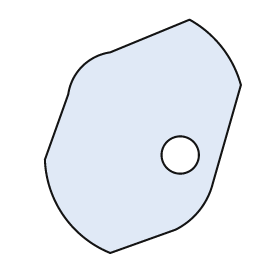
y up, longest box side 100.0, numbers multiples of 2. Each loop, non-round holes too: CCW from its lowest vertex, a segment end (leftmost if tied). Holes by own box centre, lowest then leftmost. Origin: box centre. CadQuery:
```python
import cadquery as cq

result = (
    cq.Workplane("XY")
    .moveTo(-14.0, -50.0)
    .lineTo(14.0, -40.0)
    .threePointArc((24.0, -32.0), (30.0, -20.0))
    .lineTo(42.0, 22.0)
    .threePointArc((34.0, 38.0), (20.0, 50.0))
    .lineTo(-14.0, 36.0)
    .threePointArc((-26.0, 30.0), (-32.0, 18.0))
    .lineTo(-42.0, -10.0)
    .threePointArc((-34.0, -34.0), (-14.0, -50.0))
    .close()
    .moveTo(16.0, -8.0)
    .circle(8.0)
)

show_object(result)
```